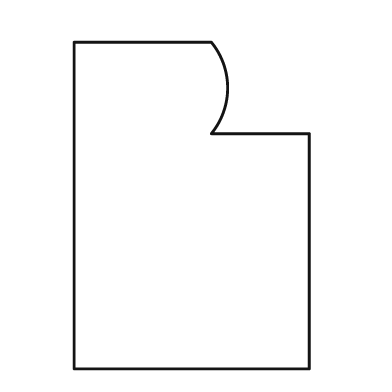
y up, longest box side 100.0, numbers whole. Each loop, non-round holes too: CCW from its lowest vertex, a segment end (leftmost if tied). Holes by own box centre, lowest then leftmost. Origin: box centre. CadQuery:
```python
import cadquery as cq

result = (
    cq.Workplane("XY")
    .moveTo(-36.0, -50.0)
    .lineTo(36.0, -50.0)
    .lineTo(36.0, 22.0)
    .lineTo(6.0, 22.0)
    .threePointArc((11.0, 36.0), (6.0, 50.0))
    .lineTo(-36.0, 50.0)
    .close()
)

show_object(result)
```